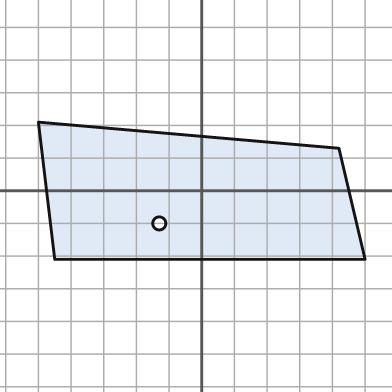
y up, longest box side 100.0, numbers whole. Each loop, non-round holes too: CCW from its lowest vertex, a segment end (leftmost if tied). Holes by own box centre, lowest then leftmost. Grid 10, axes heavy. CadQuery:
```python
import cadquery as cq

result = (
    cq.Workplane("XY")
    .moveTo(-45.0, -21.0)
    .lineTo(50.0, -21.0)
    .lineTo(42.0, 13.0)
    .lineTo(-50.0, 21.0)
    .close()
    .moveTo(-13.0, -10.0)
    .circle(2.0)
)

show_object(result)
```